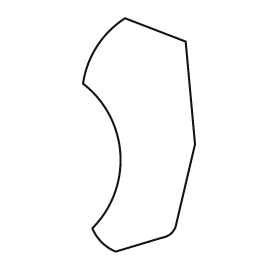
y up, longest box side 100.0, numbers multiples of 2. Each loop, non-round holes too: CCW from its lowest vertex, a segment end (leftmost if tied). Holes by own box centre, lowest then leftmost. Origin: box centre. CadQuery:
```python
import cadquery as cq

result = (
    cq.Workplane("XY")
    .moveTo(-10.0, -50.0)
    .lineTo(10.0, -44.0)
    .threePointArc((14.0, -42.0), (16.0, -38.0))
    .lineTo(24.0, -4.0)
    .lineTo(20.0, 40.0)
    .lineTo(-6.0, 50.0)
    .threePointArc((-18.0, 38.0), (-24.0, 22.0))
    .threePointArc((-8.0, -8.0), (-20.0, -40.0))
    .threePointArc((-16.0, -46.0), (-10.0, -50.0))
    .close()
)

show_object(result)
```